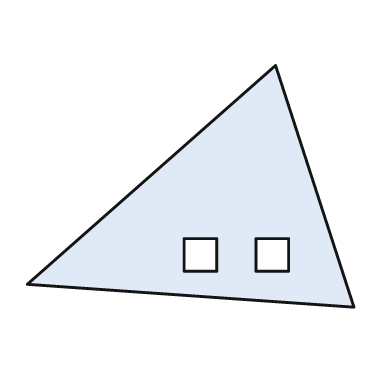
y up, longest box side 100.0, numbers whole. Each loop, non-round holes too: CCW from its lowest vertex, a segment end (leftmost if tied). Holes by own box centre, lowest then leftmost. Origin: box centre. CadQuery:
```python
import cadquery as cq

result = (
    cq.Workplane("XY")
    .moveTo(50.0, -37.0)
    .lineTo(26.0, 37.0)
    .lineTo(-50.0, -30.0)
    .close()
    .moveTo(-2.0, -26.0)
    .lineTo(8.0, -26.0)
    .lineTo(8.0, -16.0)
    .lineTo(-2.0, -16.0)
    .close()
    .moveTo(20.0, -26.0)
    .lineTo(30.0, -26.0)
    .lineTo(30.0, -16.0)
    .lineTo(20.0, -16.0)
    .close()
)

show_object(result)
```